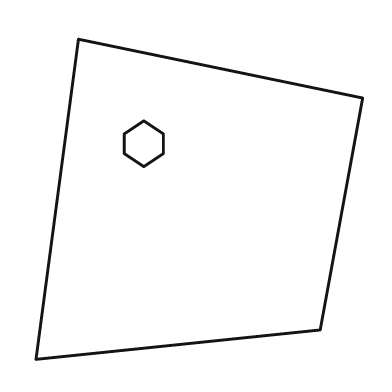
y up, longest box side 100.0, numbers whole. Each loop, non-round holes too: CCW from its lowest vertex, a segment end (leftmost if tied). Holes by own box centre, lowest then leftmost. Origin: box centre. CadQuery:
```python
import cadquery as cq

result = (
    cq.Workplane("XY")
    .moveTo(-50.0, -49.0)
    .lineTo(37.0, -40.0)
    .lineTo(50.0, 31.0)
    .lineTo(-37.0, 49.0)
    .close()
    .moveTo(-17.0, 10.0)
    .lineTo(-11.0, 14.0)
    .lineTo(-11.0, 20.0)
    .lineTo(-17.0, 24.0)
    .lineTo(-23.0, 20.0)
    .lineTo(-23.0, 14.0)
    .close()
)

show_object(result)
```